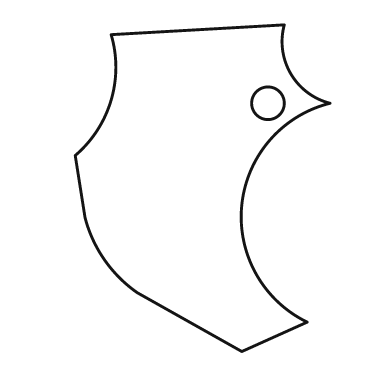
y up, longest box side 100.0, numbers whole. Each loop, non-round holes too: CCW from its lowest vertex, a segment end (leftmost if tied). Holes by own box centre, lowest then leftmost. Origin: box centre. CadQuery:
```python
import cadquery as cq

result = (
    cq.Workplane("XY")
    .moveTo(12.0, -50.0)
    .lineTo(32.0, -41.0)
    .threePointArc((12.0, -5.0), (39.0, 26.0))
    .threePointArc((27.0, 35.0), (25.0, 50.0))
    .lineTo(-28.0, 47.0)
    .threePointArc((-28.0, 27.0), (-39.0, 10.0))
    .lineTo(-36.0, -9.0)
    .threePointArc((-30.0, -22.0), (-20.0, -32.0))
    .close()
    .moveTo(20.0, 26.0)
    .circle(5.0)
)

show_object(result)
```